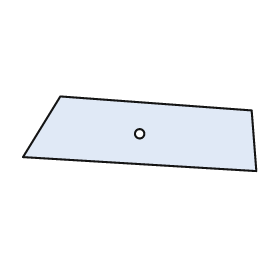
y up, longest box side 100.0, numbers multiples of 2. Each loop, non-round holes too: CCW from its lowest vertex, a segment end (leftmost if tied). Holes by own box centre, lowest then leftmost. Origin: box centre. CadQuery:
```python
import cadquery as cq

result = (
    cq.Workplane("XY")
    .moveTo(50.0, -16.0)
    .lineTo(48.0, 10.0)
    .lineTo(-34.0, 16.0)
    .lineTo(-50.0, -10.0)
    .close()
    .moveTo(0.0, 0.0)
    .circle(2.0)
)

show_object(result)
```